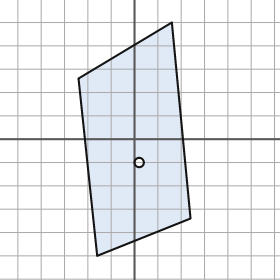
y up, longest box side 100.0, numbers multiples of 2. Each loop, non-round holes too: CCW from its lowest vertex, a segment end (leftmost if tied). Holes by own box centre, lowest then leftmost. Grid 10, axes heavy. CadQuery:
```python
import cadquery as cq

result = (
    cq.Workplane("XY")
    .moveTo(-16.0, -50.0)
    .lineTo(24.0, -34.0)
    .lineTo(16.0, 50.0)
    .lineTo(-24.0, 26.0)
    .close()
    .moveTo(2.0, -10.0)
    .circle(2.0)
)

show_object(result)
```